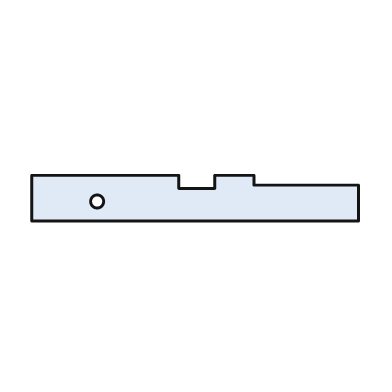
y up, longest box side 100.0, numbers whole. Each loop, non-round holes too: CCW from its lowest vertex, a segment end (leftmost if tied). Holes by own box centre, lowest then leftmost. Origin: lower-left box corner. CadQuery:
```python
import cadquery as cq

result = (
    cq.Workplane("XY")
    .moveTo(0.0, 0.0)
    .lineTo(100.0, 0.0)
    .lineTo(100.0, 11.0)
    .lineTo(68.0, 11.0)
    .lineTo(68.0, 14.0)
    .lineTo(56.0, 14.0)
    .lineTo(56.0, 10.0)
    .lineTo(45.0, 10.0)
    .lineTo(45.0, 14.0)
    .lineTo(0.0, 14.0)
    .close()
    .moveTo(20.0, 6.0)
    .circle(2.0)
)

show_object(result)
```